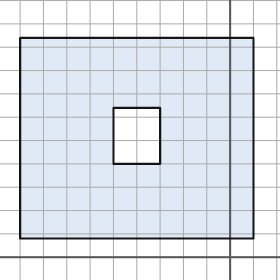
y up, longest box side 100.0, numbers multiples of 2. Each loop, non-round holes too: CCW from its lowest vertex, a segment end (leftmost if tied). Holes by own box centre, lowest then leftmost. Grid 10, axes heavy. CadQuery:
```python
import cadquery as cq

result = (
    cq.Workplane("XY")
    .moveTo(-90.0, 8.0)
    .lineTo(10.0, 8.0)
    .lineTo(10.0, 94.0)
    .lineTo(-90.0, 94.0)
    .close()
    .moveTo(-50.0, 40.0)
    .lineTo(-30.0, 40.0)
    .lineTo(-30.0, 64.0)
    .lineTo(-50.0, 64.0)
    .close()
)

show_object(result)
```